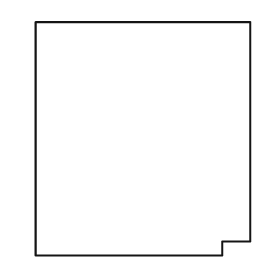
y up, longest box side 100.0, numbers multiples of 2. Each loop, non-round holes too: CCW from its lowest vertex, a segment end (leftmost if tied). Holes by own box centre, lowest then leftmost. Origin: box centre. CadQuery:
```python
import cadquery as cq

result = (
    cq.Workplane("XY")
    .moveTo(-46.0, -50.0)
    .lineTo(34.0, -50.0)
    .lineTo(34.0, -44.0)
    .lineTo(46.0, -44.0)
    .lineTo(46.0, 50.0)
    .lineTo(-46.0, 50.0)
    .close()
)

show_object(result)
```